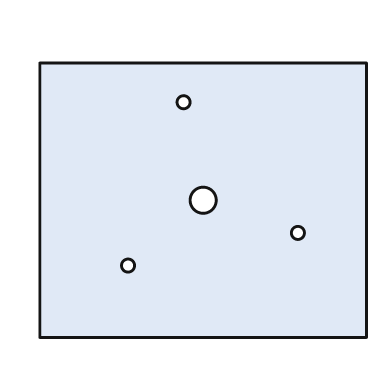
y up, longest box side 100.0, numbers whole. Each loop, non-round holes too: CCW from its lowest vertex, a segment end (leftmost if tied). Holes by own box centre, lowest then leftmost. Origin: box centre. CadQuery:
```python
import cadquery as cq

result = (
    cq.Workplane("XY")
    .moveTo(-50.0, -42.0)
    .lineTo(50.0, -42.0)
    .lineTo(50.0, 42.0)
    .lineTo(-50.0, 42.0)
    .close()
    .moveTo(-23.0, -20.0)
    .circle(2.0)
    .moveTo(29.0, -10.0)
    .circle(2.0)
    .moveTo(0.0, 0.0)
    .circle(4.0)
    .moveTo(-6.0, 30.0)
    .circle(2.0)
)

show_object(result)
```